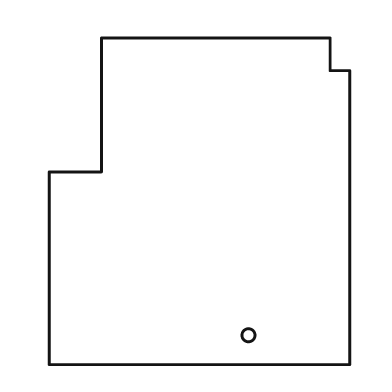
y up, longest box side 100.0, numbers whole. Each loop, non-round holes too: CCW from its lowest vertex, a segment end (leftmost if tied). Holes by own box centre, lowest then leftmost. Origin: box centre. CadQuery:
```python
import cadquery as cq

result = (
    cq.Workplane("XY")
    .moveTo(-46.0, -50.0)
    .lineTo(46.0, -50.0)
    .lineTo(46.0, 40.0)
    .lineTo(40.0, 40.0)
    .lineTo(40.0, 50.0)
    .lineTo(-30.0, 50.0)
    .lineTo(-30.0, 9.0)
    .lineTo(-46.0, 9.0)
    .close()
    .moveTo(15.0, -41.0)
    .circle(2.0)
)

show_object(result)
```